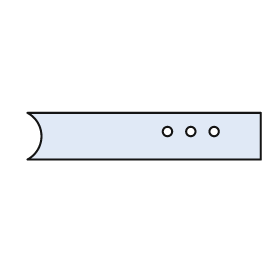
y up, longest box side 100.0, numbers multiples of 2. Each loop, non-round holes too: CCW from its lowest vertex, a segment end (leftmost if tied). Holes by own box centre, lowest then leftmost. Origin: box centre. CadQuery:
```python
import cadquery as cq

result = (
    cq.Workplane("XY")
    .moveTo(-50.0, -10.0)
    .lineTo(50.0, -10.0)
    .lineTo(50.0, 10.0)
    .lineTo(-50.0, 10.0)
    .threePointArc((-44.0, 0.0), (-50.0, -10.0))
    .close()
    .moveTo(10.0, 2.0)
    .circle(2.0)
    .moveTo(20.0, 2.0)
    .circle(2.0)
    .moveTo(30.0, 2.0)
    .circle(2.0)
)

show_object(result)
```